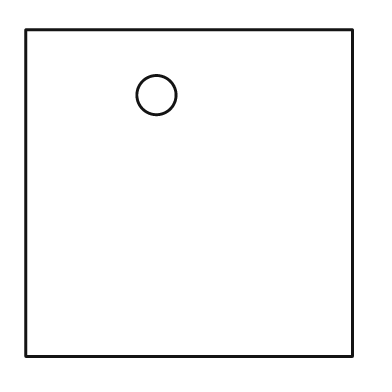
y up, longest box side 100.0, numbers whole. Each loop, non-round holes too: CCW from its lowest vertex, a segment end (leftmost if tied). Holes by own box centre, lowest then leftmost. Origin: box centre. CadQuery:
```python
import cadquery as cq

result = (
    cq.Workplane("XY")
    .moveTo(-50.0, -50.0)
    .lineTo(50.0, -50.0)
    .lineTo(50.0, 50.0)
    .lineTo(-50.0, 50.0)
    .close()
    .moveTo(-10.0, 30.0)
    .circle(6.0)
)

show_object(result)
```